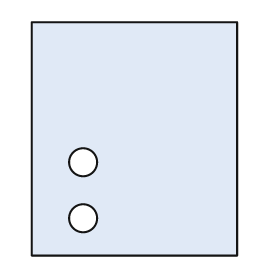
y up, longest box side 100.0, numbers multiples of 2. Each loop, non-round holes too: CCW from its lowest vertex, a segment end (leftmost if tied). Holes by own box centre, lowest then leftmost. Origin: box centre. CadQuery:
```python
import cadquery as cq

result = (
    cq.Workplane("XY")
    .moveTo(-44.0, -50.0)
    .lineTo(44.0, -50.0)
    .lineTo(44.0, 50.0)
    .lineTo(-44.0, 50.0)
    .close()
    .moveTo(-22.0, -34.0)
    .circle(6.0)
    .moveTo(-22.0, -10.0)
    .circle(6.0)
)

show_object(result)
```